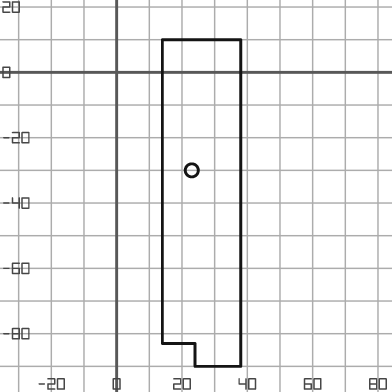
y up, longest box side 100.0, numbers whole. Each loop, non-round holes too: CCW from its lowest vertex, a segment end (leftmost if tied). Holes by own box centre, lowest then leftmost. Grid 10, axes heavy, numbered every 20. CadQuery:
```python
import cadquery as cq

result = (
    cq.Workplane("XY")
    .moveTo(24.0, -90.0)
    .lineTo(38.0, -90.0)
    .lineTo(38.0, 10.0)
    .lineTo(14.0, 10.0)
    .lineTo(14.0, -83.0)
    .lineTo(24.0, -83.0)
    .close()
    .moveTo(23.0, -30.0)
    .circle(2.0)
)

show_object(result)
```